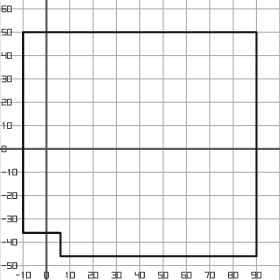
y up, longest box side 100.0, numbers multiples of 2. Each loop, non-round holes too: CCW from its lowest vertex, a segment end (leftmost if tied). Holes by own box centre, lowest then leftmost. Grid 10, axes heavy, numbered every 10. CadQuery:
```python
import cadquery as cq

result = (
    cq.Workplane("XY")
    .moveTo(6.0, -46.0)
    .lineTo(90.0, -46.0)
    .lineTo(90.0, 50.0)
    .lineTo(-10.0, 50.0)
    .lineTo(-10.0, -36.0)
    .lineTo(6.0, -36.0)
    .close()
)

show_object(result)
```